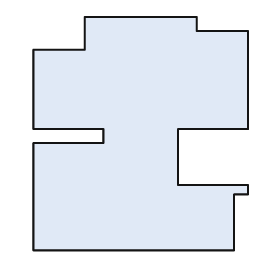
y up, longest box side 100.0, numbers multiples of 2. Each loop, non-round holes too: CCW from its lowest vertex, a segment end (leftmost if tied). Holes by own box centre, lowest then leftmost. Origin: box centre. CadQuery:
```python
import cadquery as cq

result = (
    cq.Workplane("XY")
    .moveTo(-46.0, -50.0)
    .lineTo(40.0, -50.0)
    .lineTo(40.0, -26.0)
    .lineTo(46.0, -26.0)
    .lineTo(46.0, -22.0)
    .lineTo(16.0, -22.0)
    .lineTo(16.0, 2.0)
    .lineTo(46.0, 2.0)
    .lineTo(46.0, 44.0)
    .lineTo(24.0, 44.0)
    .lineTo(24.0, 50.0)
    .lineTo(-24.0, 50.0)
    .lineTo(-24.0, 36.0)
    .lineTo(-46.0, 36.0)
    .lineTo(-46.0, 2.0)
    .lineTo(-16.0, 2.0)
    .lineTo(-16.0, -4.0)
    .lineTo(-46.0, -4.0)
    .close()
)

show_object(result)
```